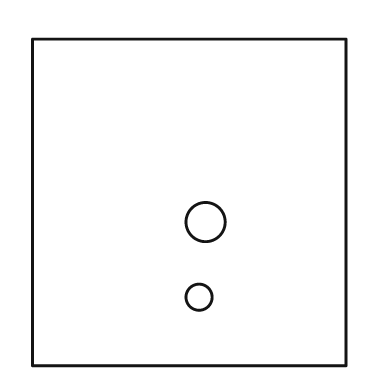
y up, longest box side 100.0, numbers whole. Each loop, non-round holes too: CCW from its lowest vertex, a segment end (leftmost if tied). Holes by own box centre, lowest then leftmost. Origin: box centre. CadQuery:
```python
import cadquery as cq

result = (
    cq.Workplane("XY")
    .moveTo(-48.0, -50.0)
    .lineTo(48.0, -50.0)
    .lineTo(48.0, 50.0)
    .lineTo(-48.0, 50.0)
    .close()
    .moveTo(3.0, -29.0)
    .circle(4.0)
    .moveTo(5.0, -6.0)
    .circle(6.0)
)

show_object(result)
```